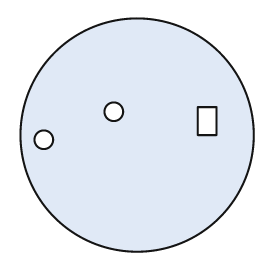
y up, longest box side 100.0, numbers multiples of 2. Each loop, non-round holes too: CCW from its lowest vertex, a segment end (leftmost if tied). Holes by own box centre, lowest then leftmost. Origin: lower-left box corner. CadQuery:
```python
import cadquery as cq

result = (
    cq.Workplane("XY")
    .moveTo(50.0, 50.0)
    .circle(50.0)
    .moveTo(10.0, 48.0)
    .circle(4.0)
    .moveTo(76.0, 50.0)
    .lineTo(84.0, 50.0)
    .lineTo(84.0, 62.0)
    .lineTo(76.0, 62.0)
    .close()
    .moveTo(40.0, 60.0)
    .circle(4.0)
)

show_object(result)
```